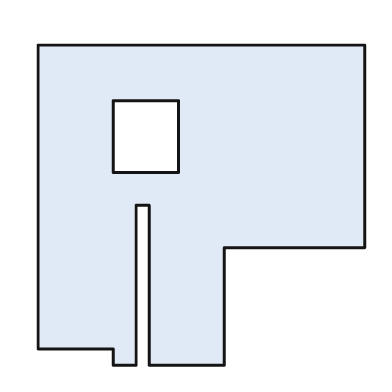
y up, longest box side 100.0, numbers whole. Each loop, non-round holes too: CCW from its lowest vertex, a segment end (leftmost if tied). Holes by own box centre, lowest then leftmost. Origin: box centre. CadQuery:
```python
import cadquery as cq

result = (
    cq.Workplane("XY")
    .moveTo(-27.0, -49.0)
    .lineTo(-20.0, -49.0)
    .lineTo(-20.0, 0.0)
    .lineTo(-16.0, 0.0)
    .lineTo(-16.0, -49.0)
    .lineTo(7.0, -49.0)
    .lineTo(7.0, -13.0)
    .lineTo(50.0, -13.0)
    .lineTo(50.0, 49.0)
    .lineTo(-50.0, 49.0)
    .lineTo(-50.0, -44.0)
    .lineTo(-27.0, -44.0)
    .close()
    .moveTo(-27.0, 10.0)
    .lineTo(-7.0, 10.0)
    .lineTo(-7.0, 32.0)
    .lineTo(-27.0, 32.0)
    .close()
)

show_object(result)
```